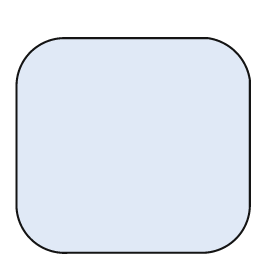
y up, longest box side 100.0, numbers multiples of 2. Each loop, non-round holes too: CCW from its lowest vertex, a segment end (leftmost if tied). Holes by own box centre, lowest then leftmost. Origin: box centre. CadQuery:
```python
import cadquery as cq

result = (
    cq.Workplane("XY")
    .moveTo(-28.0, -46.0)
    .lineTo(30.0, -46.0)
    .threePointArc((44.0, -40.0), (50.0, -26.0))
    .lineTo(50.0, 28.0)
    .threePointArc((44.0, 40.0), (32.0, 46.0))
    .lineTo(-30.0, 46.0)
    .threePointArc((-44.0, 40.0), (-50.0, 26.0))
    .lineTo(-50.0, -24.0)
    .threePointArc((-44.0, -40.0), (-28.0, -46.0))
    .close()
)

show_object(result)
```